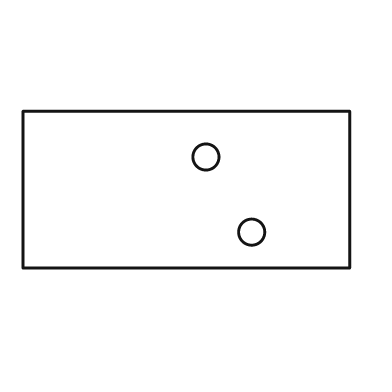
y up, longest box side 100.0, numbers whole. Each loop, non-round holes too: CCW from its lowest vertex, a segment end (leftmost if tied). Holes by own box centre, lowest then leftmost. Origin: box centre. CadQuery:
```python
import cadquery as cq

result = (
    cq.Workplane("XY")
    .moveTo(-50.0, -24.0)
    .lineTo(50.0, -24.0)
    .lineTo(50.0, 24.0)
    .lineTo(-50.0, 24.0)
    .close()
    .moveTo(20.0, -13.0)
    .circle(4.0)
    .moveTo(6.0, 10.0)
    .circle(4.0)
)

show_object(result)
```